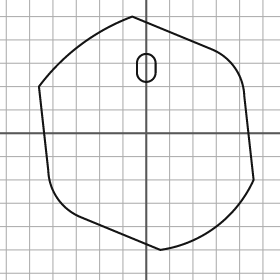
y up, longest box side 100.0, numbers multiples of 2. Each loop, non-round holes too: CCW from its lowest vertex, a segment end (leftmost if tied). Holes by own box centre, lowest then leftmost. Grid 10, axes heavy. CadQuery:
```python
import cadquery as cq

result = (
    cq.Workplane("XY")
    .moveTo(6.0, -50.0)
    .threePointArc((30.0, -40.0), (46.0, -20.0))
    .lineTo(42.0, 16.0)
    .threePointArc((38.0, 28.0), (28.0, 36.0))
    .lineTo(-6.0, 50.0)
    .threePointArc((-28.0, 38.0), (-46.0, 20.0))
    .lineTo(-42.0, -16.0)
    .threePointArc((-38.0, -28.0), (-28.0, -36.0))
    .close()
    .moveTo(-4.0, 26.0)
    .threePointArc((0.0, 22.0), (4.0, 26.0))
    .lineTo(4.0, 30.0)
    .threePointArc((0.0, 34.0), (-4.0, 30.0))
    .close()
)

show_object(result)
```